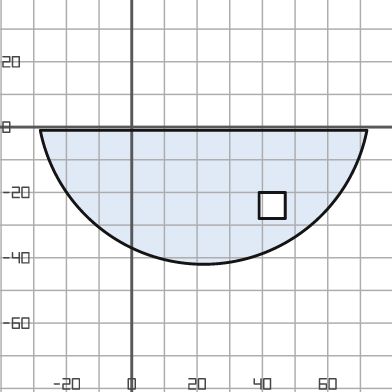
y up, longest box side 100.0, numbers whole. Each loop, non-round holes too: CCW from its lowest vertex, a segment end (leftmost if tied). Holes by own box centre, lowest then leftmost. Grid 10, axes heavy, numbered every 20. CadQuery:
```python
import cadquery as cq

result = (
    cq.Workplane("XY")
    .moveTo(-28.0, -1.0)
    .threePointArc((22.0, -42.0), (72.0, -1.0))
    .close()
    .moveTo(39.0, -28.0)
    .lineTo(47.0, -28.0)
    .lineTo(47.0, -20.0)
    .lineTo(39.0, -20.0)
    .close()
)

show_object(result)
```